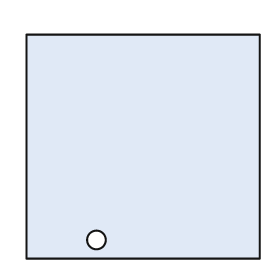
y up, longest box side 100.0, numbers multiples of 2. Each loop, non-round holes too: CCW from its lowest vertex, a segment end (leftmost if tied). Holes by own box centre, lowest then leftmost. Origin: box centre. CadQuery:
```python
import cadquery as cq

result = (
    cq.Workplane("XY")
    .moveTo(-50.0, -48.0)
    .lineTo(50.0, -48.0)
    .lineTo(50.0, 48.0)
    .lineTo(-50.0, 48.0)
    .close()
    .moveTo(-20.0, -40.0)
    .circle(4.0)
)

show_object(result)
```